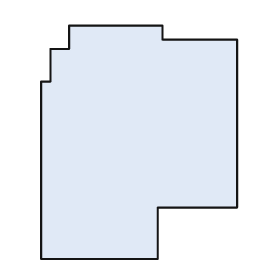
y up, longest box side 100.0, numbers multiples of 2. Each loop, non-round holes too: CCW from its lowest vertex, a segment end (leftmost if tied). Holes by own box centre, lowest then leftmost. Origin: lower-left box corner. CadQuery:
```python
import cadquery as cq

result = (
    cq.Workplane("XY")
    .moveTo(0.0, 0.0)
    .lineTo(50.0, 0.0)
    .lineTo(50.0, 22.0)
    .lineTo(84.0, 22.0)
    .lineTo(84.0, 94.0)
    .lineTo(52.0, 94.0)
    .lineTo(52.0, 100.0)
    .lineTo(12.0, 100.0)
    .lineTo(12.0, 90.0)
    .lineTo(4.0, 90.0)
    .lineTo(4.0, 76.0)
    .lineTo(0.0, 76.0)
    .close()
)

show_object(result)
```